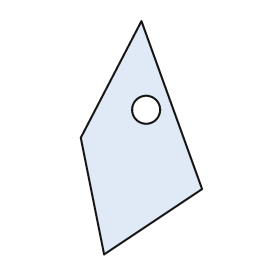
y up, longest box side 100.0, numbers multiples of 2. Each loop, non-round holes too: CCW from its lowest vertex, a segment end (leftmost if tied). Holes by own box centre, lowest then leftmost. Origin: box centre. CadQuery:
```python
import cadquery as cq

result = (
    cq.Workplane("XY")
    .moveTo(-16.0, -50.0)
    .lineTo(26.0, -22.0)
    .lineTo(0.0, 50.0)
    .lineTo(-26.0, 0.0)
    .close()
    .moveTo(2.0, 12.0)
    .circle(6.0)
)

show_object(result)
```